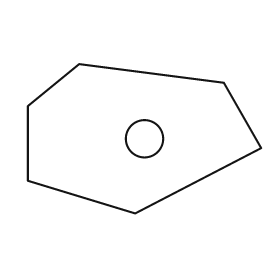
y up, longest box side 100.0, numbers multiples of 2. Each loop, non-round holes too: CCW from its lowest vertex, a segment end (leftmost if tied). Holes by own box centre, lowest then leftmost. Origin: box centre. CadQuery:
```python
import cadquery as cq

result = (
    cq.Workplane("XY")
    .moveTo(-4.0, -32.0)
    .lineTo(50.0, -4.0)
    .lineTo(34.0, 24.0)
    .lineTo(-28.0, 32.0)
    .lineTo(-50.0, 14.0)
    .lineTo(-50.0, -18.0)
    .close()
    .moveTo(0.0, 0.0)
    .circle(8.0)
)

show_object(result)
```